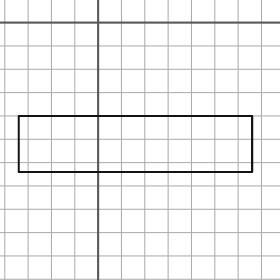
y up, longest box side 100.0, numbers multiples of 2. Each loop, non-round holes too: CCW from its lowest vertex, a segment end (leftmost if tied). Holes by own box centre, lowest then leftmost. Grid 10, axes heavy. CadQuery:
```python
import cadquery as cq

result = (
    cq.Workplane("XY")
    .moveTo(-34.0, -64.0)
    .lineTo(66.0, -64.0)
    .lineTo(66.0, -40.0)
    .lineTo(-34.0, -40.0)
    .close()
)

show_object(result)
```